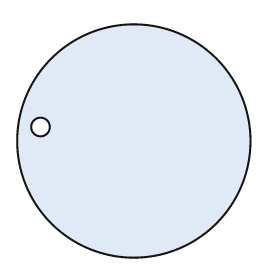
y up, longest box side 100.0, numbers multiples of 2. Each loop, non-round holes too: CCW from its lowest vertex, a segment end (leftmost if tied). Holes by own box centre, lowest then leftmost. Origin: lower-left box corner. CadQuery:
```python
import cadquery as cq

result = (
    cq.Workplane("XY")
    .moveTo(50.0, 50.0)
    .circle(50.0)
    .moveTo(10.0, 56.0)
    .circle(4.0)
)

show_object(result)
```